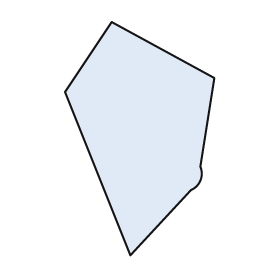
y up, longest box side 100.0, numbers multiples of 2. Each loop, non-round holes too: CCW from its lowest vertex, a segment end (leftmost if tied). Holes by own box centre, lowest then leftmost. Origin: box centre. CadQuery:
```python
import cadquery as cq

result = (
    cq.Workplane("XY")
    .moveTo(-4.0, -50.0)
    .lineTo(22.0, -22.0)
    .threePointArc((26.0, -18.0), (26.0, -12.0))
    .lineTo(32.0, 26.0)
    .lineTo(-12.0, 50.0)
    .lineTo(-32.0, 20.0)
    .close()
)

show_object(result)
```